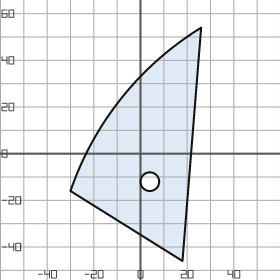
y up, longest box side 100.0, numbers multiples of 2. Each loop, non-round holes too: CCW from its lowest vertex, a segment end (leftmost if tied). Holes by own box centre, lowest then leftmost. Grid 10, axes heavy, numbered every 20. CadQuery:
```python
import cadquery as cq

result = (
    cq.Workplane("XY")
    .moveTo(18.0, -46.0)
    .lineTo(26.0, 54.0)
    .threePointArc((-8.0, 24.0), (-30.0, -16.0))
    .close()
    .moveTo(4.0, -12.0)
    .circle(4.0)
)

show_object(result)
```